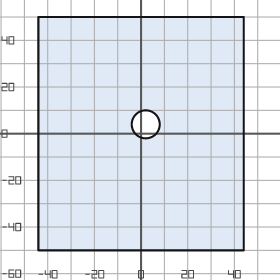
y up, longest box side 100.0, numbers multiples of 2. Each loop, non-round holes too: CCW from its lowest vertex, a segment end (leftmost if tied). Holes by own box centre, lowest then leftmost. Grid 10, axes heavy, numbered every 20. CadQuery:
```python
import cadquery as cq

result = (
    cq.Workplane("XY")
    .moveTo(-44.0, -50.0)
    .lineTo(44.0, -50.0)
    .lineTo(44.0, 50.0)
    .lineTo(-44.0, 50.0)
    .close()
    .moveTo(2.0, 4.0)
    .circle(6.0)
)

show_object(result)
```